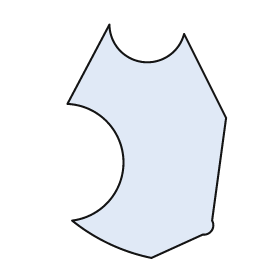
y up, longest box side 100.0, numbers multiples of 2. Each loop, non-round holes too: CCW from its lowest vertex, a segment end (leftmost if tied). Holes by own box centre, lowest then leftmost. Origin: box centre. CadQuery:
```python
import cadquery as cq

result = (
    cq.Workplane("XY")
    .moveTo(2.0, -50.0)
    .lineTo(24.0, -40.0)
    .threePointArc((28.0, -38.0), (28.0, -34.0))
    .lineTo(34.0, 10.0)
    .lineTo(16.0, 46.0)
    .threePointArc((-2.0, 34.0), (-16.0, 50.0))
    .lineTo(-34.0, 16.0)
    .threePointArc((-10.0, -8.0), (-32.0, -34.0))
    .threePointArc((-16.0, -44.0), (2.0, -50.0))
    .close()
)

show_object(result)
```